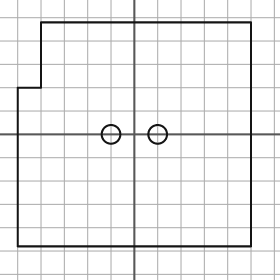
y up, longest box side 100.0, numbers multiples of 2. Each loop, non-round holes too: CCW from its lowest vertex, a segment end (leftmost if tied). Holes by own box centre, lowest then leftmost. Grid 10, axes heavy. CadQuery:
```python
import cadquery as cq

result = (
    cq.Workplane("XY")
    .moveTo(-50.0, -48.0)
    .lineTo(50.0, -48.0)
    .lineTo(50.0, 48.0)
    .lineTo(-40.0, 48.0)
    .lineTo(-40.0, 20.0)
    .lineTo(-50.0, 20.0)
    .close()
    .moveTo(-10.0, 0.0)
    .circle(4.0)
    .moveTo(10.0, 0.0)
    .circle(4.0)
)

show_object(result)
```